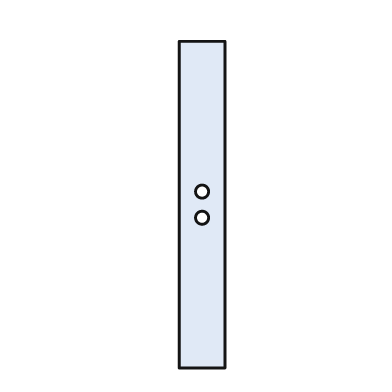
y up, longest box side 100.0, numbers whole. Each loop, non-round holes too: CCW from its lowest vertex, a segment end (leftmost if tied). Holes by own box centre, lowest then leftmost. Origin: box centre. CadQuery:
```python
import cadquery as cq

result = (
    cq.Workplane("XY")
    .moveTo(-7.0, -50.0)
    .lineTo(7.0, -50.0)
    .lineTo(7.0, 50.0)
    .lineTo(-7.0, 50.0)
    .close()
    .moveTo(0.0, -4.0)
    .circle(2.0)
    .moveTo(0.0, 4.0)
    .circle(2.0)
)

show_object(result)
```